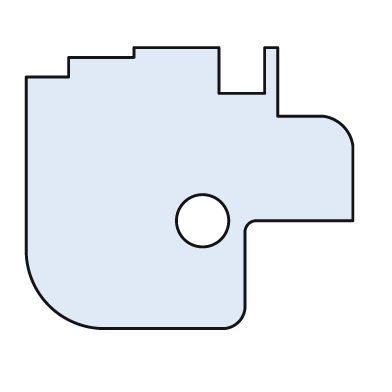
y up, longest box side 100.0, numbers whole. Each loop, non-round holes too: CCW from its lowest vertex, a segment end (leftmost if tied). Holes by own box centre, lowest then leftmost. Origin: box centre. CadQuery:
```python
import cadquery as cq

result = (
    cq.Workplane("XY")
    .moveTo(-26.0, -43.0)
    .lineTo(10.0, -43.0)
    .threePointArc((15.0, -41.0), (17.0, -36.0))
    .lineTo(17.0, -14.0)
    .threePointArc((18.0, -11.0), (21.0, -10.0))
    .lineTo(50.0, -10.0)
    .lineTo(50.0, 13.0)
    .threePointArc((47.0, 19.0), (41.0, 22.0))
    .lineTo(27.0, 22.0)
    .lineTo(27.0, 43.0)
    .lineTo(23.0, 43.0)
    .lineTo(23.0, 29.0)
    .lineTo(9.0, 29.0)
    .lineTo(9.0, 43.0)
    .lineTo(-17.0, 43.0)
    .lineTo(-17.0, 40.0)
    .lineTo(-37.0, 40.0)
    .lineTo(-37.0, 34.0)
    .lineTo(-50.0, 34.0)
    .lineTo(-50.0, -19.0)
    .threePointArc((-43.0, -36.0), (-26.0, -43.0))
    .close()
    .moveTo(4.0, -10.0)
    .circle(8.0)
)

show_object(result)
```